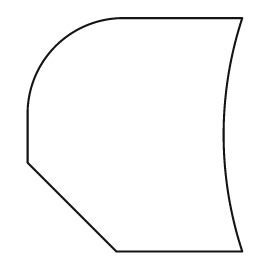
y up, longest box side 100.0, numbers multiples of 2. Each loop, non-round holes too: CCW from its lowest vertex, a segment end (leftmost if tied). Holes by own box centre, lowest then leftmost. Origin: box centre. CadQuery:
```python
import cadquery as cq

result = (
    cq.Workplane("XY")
    .moveTo(-8.0, -50.0)
    .lineTo(46.0, -50.0)
    .threePointArc((38.0, 0.0), (46.0, 50.0))
    .lineTo(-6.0, 50.0)
    .threePointArc((-34.0, 38.0), (-46.0, 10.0))
    .lineTo(-46.0, -12.0)
    .close()
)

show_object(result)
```